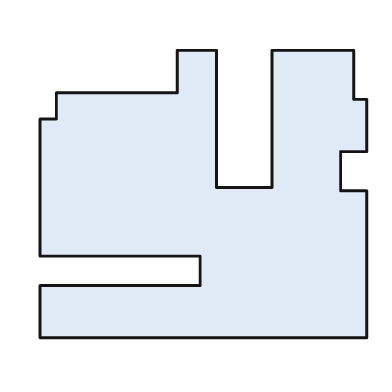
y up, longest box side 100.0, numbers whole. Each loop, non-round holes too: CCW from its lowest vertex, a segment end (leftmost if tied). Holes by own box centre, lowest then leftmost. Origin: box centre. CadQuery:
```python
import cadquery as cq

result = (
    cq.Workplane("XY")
    .moveTo(-50.0, -44.0)
    .lineTo(50.0, -44.0)
    .lineTo(50.0, 1.0)
    .lineTo(42.0, 1.0)
    .lineTo(42.0, 13.0)
    .lineTo(50.0, 13.0)
    .lineTo(50.0, 29.0)
    .lineTo(46.0, 29.0)
    .lineTo(46.0, 44.0)
    .lineTo(21.0, 44.0)
    .lineTo(21.0, 2.0)
    .lineTo(4.0, 2.0)
    .lineTo(4.0, 44.0)
    .lineTo(-8.0, 44.0)
    .lineTo(-8.0, 31.0)
    .lineTo(-45.0, 31.0)
    .lineTo(-45.0, 23.0)
    .lineTo(-50.0, 23.0)
    .lineTo(-50.0, -19.0)
    .lineTo(-1.0, -19.0)
    .lineTo(-1.0, -28.0)
    .lineTo(-50.0, -28.0)
    .close()
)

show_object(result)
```